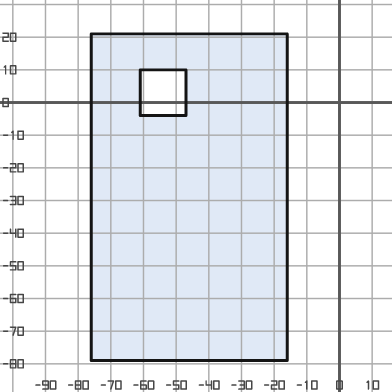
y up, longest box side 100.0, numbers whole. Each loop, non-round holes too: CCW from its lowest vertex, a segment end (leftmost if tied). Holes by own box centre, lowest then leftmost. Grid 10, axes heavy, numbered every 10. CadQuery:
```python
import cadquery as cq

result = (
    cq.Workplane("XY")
    .moveTo(-76.0, -79.0)
    .lineTo(-16.0, -79.0)
    .lineTo(-16.0, 21.0)
    .lineTo(-76.0, 21.0)
    .close()
    .moveTo(-61.0, -4.0)
    .lineTo(-47.0, -4.0)
    .lineTo(-47.0, 10.0)
    .lineTo(-61.0, 10.0)
    .close()
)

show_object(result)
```